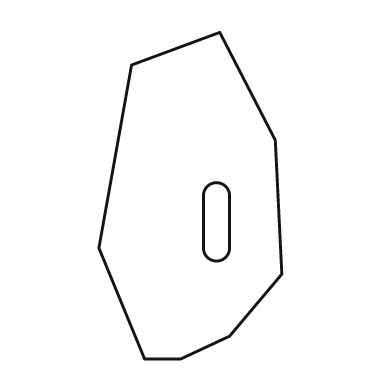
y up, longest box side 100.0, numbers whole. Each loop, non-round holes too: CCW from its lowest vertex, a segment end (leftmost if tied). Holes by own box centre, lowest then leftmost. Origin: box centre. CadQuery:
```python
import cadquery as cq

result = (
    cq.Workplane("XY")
    .moveTo(-14.0, -50.0)
    .lineTo(-3.0, -50.0)
    .lineTo(12.0, -43.0)
    .lineTo(28.0, -24.0)
    .lineTo(26.0, 17.0)
    .lineTo(9.0, 50.0)
    .lineTo(-18.0, 40.0)
    .lineTo(-28.0, -16.0)
    .close()
    .moveTo(4.0, -16.0)
    .threePointArc((8.0, -20.0), (12.0, -16.0))
    .lineTo(12.0, 0.0)
    .threePointArc((8.0, 4.0), (4.0, 0.0))
    .close()
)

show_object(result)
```